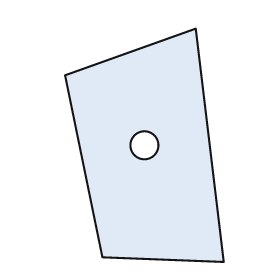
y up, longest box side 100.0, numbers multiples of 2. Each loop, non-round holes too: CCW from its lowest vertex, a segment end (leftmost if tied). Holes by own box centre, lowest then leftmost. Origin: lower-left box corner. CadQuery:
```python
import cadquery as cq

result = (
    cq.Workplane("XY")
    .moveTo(68.0, 0.0)
    .lineTo(56.0, 100.0)
    .lineTo(0.0, 80.0)
    .lineTo(16.0, 2.0)
    .close()
    .moveTo(34.0, 50.0)
    .circle(6.0)
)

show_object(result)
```